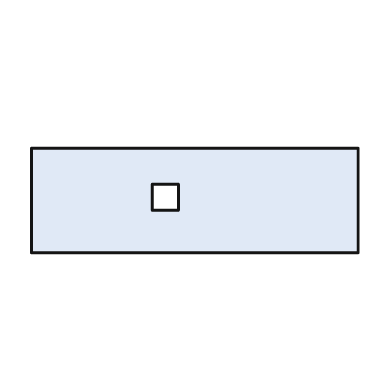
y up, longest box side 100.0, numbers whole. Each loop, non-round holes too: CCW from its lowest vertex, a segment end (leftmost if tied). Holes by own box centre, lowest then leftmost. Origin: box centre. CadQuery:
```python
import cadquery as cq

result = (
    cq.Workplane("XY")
    .moveTo(-50.0, -16.0)
    .lineTo(50.0, -16.0)
    .lineTo(50.0, 16.0)
    .lineTo(-50.0, 16.0)
    .close()
    .moveTo(-13.0, -3.0)
    .lineTo(-5.0, -3.0)
    .lineTo(-5.0, 5.0)
    .lineTo(-13.0, 5.0)
    .close()
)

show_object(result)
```